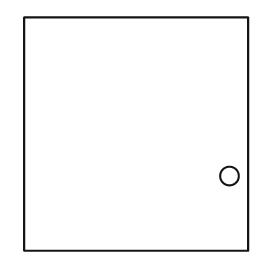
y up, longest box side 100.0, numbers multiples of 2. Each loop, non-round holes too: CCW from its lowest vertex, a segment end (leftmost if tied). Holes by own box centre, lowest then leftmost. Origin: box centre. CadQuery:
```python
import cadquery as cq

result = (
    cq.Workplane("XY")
    .moveTo(-48.0, -50.0)
    .lineTo(48.0, -50.0)
    .lineTo(48.0, 50.0)
    .lineTo(-48.0, 50.0)
    .close()
    .moveTo(40.0, -18.0)
    .circle(4.0)
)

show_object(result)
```